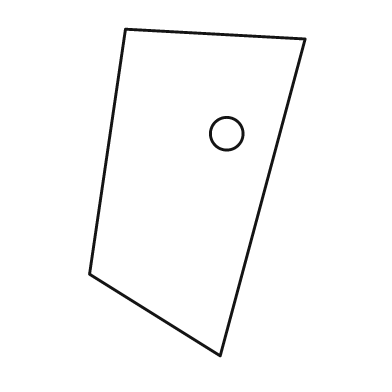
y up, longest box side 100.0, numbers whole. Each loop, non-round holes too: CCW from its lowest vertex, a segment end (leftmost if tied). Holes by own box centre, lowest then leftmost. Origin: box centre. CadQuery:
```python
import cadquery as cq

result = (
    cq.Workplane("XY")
    .moveTo(7.0, -50.0)
    .lineTo(33.0, 47.0)
    .lineTo(-22.0, 50.0)
    .lineTo(-33.0, -25.0)
    .close()
    .moveTo(9.0, 18.0)
    .circle(5.0)
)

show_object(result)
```